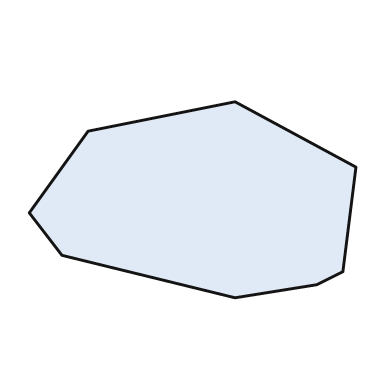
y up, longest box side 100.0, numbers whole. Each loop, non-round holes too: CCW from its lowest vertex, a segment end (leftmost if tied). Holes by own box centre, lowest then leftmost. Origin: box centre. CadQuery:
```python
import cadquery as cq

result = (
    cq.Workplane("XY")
    .moveTo(13.0, -30.0)
    .lineTo(38.0, -26.0)
    .lineTo(46.0, -22.0)
    .lineTo(50.0, 10.0)
    .lineTo(13.0, 30.0)
    .lineTo(-32.0, 21.0)
    .lineTo(-50.0, -4.0)
    .lineTo(-40.0, -17.0)
    .close()
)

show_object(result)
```